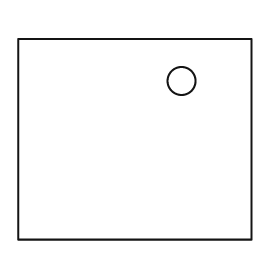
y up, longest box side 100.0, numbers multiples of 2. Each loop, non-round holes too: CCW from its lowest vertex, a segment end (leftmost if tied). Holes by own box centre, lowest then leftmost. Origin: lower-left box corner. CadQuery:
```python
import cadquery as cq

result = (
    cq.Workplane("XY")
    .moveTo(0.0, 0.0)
    .lineTo(100.0, 0.0)
    .lineTo(100.0, 86.0)
    .lineTo(0.0, 86.0)
    .close()
    .moveTo(70.0, 68.0)
    .circle(6.0)
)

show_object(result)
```